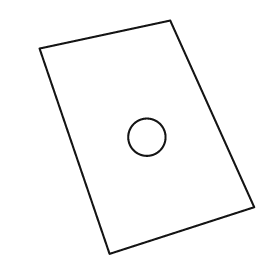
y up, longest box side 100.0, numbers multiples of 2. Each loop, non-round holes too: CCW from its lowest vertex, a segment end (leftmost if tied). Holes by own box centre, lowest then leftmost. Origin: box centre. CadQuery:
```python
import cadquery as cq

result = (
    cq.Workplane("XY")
    .moveTo(-16.0, -50.0)
    .lineTo(46.0, -30.0)
    .lineTo(10.0, 50.0)
    .lineTo(-46.0, 38.0)
    .close()
    .moveTo(0.0, 0.0)
    .circle(8.0)
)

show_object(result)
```